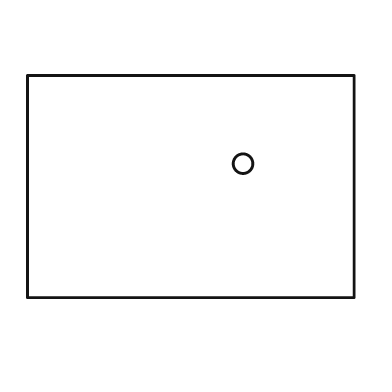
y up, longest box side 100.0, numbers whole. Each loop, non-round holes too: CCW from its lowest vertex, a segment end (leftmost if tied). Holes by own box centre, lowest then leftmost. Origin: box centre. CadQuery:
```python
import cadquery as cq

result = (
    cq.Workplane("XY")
    .moveTo(-50.0, -34.0)
    .lineTo(50.0, -34.0)
    .lineTo(50.0, 34.0)
    .lineTo(-50.0, 34.0)
    .close()
    .moveTo(16.0, 7.0)
    .circle(3.0)
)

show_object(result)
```